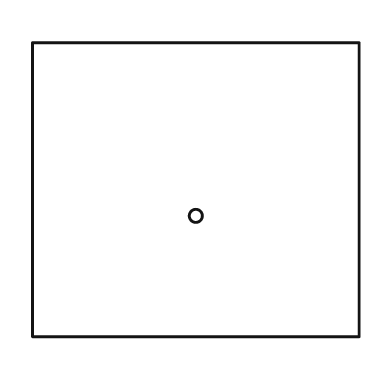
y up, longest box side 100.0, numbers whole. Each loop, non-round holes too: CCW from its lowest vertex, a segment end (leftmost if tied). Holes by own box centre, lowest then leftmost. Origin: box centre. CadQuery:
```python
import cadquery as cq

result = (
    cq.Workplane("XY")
    .moveTo(-50.0, -45.0)
    .lineTo(50.0, -45.0)
    .lineTo(50.0, 45.0)
    .lineTo(-50.0, 45.0)
    .close()
    .moveTo(0.0, -8.0)
    .circle(2.0)
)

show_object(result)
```